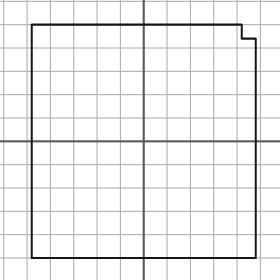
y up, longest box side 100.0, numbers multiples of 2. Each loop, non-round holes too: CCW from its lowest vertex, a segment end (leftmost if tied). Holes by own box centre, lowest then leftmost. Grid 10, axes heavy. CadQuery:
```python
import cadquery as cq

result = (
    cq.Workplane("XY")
    .moveTo(-48.0, -50.0)
    .lineTo(48.0, -50.0)
    .lineTo(48.0, 44.0)
    .lineTo(42.0, 44.0)
    .lineTo(42.0, 50.0)
    .lineTo(-48.0, 50.0)
    .close()
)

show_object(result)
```